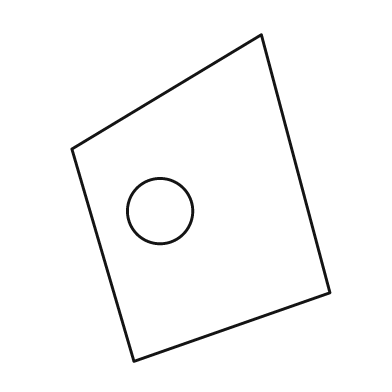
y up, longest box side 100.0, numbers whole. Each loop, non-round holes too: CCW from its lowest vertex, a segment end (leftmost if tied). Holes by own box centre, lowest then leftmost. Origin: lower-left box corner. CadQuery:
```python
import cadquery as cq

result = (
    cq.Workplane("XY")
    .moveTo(19.0, 0.0)
    .lineTo(79.0, 21.0)
    .lineTo(58.0, 100.0)
    .lineTo(0.0, 65.0)
    .close()
    .moveTo(27.0, 46.0)
    .circle(10.0)
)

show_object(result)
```